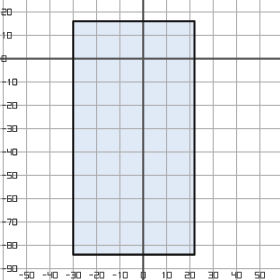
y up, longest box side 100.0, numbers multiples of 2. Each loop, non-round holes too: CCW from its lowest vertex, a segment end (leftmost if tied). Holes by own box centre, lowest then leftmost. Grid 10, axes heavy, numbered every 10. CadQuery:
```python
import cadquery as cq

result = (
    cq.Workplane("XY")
    .moveTo(-30.0, -84.0)
    .lineTo(22.0, -84.0)
    .lineTo(22.0, 16.0)
    .lineTo(-30.0, 16.0)
    .close()
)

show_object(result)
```